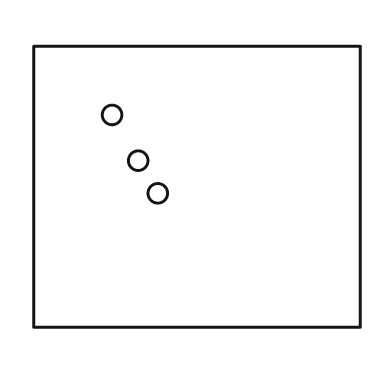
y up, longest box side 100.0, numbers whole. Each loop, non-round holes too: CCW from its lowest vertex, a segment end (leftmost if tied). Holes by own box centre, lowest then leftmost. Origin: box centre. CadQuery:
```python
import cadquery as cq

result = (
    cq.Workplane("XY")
    .moveTo(-50.0, -43.0)
    .lineTo(50.0, -43.0)
    .lineTo(50.0, 43.0)
    .lineTo(-50.0, 43.0)
    .close()
    .moveTo(-12.0, -2.0)
    .circle(3.0)
    .moveTo(-18.0, 8.0)
    .circle(3.0)
    .moveTo(-26.0, 22.0)
    .circle(3.0)
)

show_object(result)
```